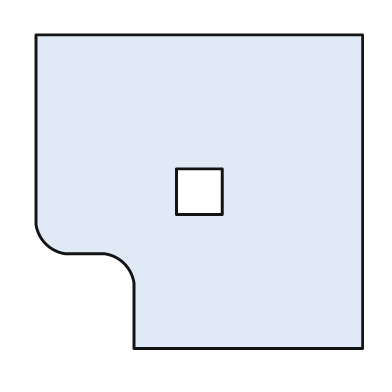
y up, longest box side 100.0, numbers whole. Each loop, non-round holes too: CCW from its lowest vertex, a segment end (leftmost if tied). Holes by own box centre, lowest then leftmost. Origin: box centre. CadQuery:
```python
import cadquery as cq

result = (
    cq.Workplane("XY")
    .moveTo(-20.0, -48.0)
    .lineTo(50.0, -48.0)
    .lineTo(50.0, 48.0)
    .lineTo(-50.0, 48.0)
    .lineTo(-50.0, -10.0)
    .threePointArc((-47.0, -16.0), (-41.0, -19.0))
    .lineTo(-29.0, -19.0)
    .threePointArc((-23.0, -22.0), (-20.0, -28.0))
    .close()
    .moveTo(-7.0, -7.0)
    .lineTo(7.0, -7.0)
    .lineTo(7.0, 7.0)
    .lineTo(-7.0, 7.0)
    .close()
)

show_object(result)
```